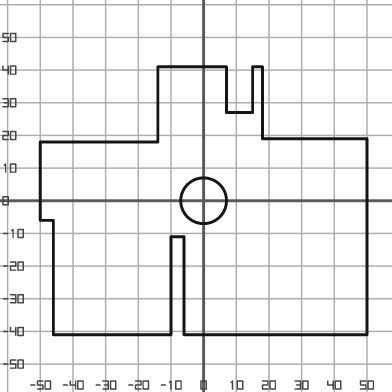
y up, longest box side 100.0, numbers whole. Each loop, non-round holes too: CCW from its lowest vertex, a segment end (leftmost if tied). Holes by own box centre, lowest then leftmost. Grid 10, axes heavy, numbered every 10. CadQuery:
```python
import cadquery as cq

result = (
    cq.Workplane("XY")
    .moveTo(-46.0, -41.0)
    .lineTo(-10.0, -41.0)
    .lineTo(-10.0, -11.0)
    .lineTo(-6.0, -11.0)
    .lineTo(-6.0, -41.0)
    .lineTo(50.0, -41.0)
    .lineTo(50.0, 19.0)
    .lineTo(18.0, 19.0)
    .lineTo(18.0, 41.0)
    .lineTo(15.0, 41.0)
    .lineTo(15.0, 27.0)
    .lineTo(7.0, 27.0)
    .lineTo(7.0, 41.0)
    .lineTo(-14.0, 41.0)
    .lineTo(-14.0, 18.0)
    .lineTo(-50.0, 18.0)
    .lineTo(-50.0, -6.0)
    .lineTo(-46.0, -6.0)
    .close()
    .moveTo(0.0, 0.0)
    .circle(7.0)
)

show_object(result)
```